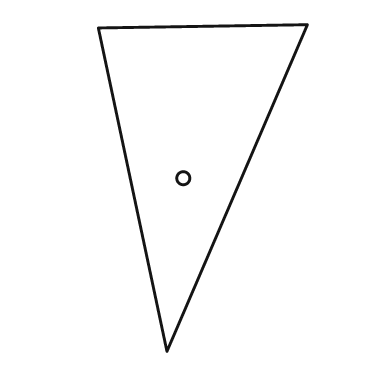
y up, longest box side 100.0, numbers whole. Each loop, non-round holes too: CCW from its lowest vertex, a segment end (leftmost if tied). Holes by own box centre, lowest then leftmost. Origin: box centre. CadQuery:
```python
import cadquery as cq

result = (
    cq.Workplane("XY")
    .moveTo(-11.0, -50.0)
    .lineTo(32.0, 50.0)
    .lineTo(-32.0, 49.0)
    .close()
    .moveTo(-6.0, 3.0)
    .circle(2.0)
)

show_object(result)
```